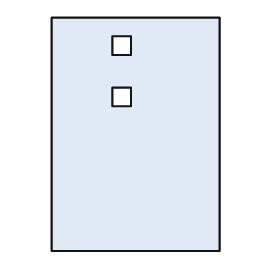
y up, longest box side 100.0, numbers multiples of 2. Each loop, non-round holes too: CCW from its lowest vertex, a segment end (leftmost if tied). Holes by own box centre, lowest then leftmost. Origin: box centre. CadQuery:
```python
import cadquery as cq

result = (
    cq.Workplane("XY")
    .moveTo(-36.0, -50.0)
    .lineTo(36.0, -50.0)
    .lineTo(36.0, 50.0)
    .lineTo(-36.0, 50.0)
    .close()
    .moveTo(-10.0, 12.0)
    .lineTo(-2.0, 12.0)
    .lineTo(-2.0, 20.0)
    .lineTo(-10.0, 20.0)
    .close()
    .moveTo(-10.0, 34.0)
    .lineTo(-2.0, 34.0)
    .lineTo(-2.0, 42.0)
    .lineTo(-10.0, 42.0)
    .close()
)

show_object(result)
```